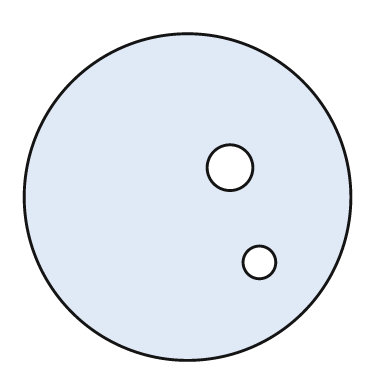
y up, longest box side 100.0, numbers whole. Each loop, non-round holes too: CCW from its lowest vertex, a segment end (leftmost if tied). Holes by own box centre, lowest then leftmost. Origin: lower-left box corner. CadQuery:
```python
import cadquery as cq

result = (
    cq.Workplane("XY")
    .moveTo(50.0, 50.0)
    .circle(50.0)
    .moveTo(72.0, 30.0)
    .circle(5.0)
    .moveTo(63.0, 59.0)
    .circle(7.0)
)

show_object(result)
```